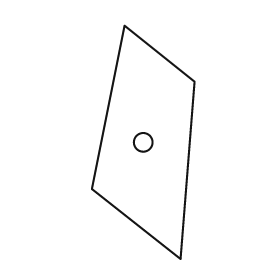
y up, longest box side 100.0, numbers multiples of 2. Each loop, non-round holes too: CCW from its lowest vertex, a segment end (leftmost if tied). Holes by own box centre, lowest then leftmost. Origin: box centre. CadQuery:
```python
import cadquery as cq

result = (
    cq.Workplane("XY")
    .moveTo(16.0, -50.0)
    .lineTo(22.0, 26.0)
    .lineTo(-8.0, 50.0)
    .lineTo(-22.0, -20.0)
    .close()
    .moveTo(0.0, 0.0)
    .circle(4.0)
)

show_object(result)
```